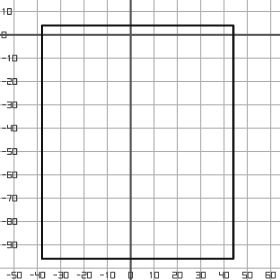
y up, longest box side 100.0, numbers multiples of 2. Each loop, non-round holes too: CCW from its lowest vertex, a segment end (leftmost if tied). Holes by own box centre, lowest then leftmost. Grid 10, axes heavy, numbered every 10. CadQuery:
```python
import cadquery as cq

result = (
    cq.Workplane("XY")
    .moveTo(-38.0, -96.0)
    .lineTo(44.0, -96.0)
    .lineTo(44.0, 4.0)
    .lineTo(-38.0, 4.0)
    .close()
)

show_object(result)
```